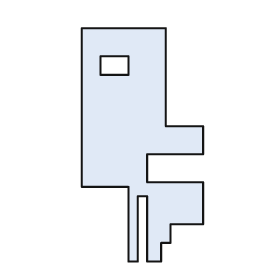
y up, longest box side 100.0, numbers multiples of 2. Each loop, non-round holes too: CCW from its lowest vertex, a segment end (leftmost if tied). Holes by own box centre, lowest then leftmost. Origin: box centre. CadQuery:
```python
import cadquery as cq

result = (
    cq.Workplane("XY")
    .moveTo(-6.0, -50.0)
    .lineTo(-2.0, -50.0)
    .lineTo(-2.0, -22.0)
    .lineTo(2.0, -22.0)
    .lineTo(2.0, -50.0)
    .lineTo(8.0, -50.0)
    .lineTo(8.0, -42.0)
    .lineTo(12.0, -42.0)
    .lineTo(12.0, -34.0)
    .lineTo(26.0, -34.0)
    .lineTo(26.0, -16.0)
    .lineTo(2.0, -16.0)
    .lineTo(2.0, -4.0)
    .lineTo(26.0, -4.0)
    .lineTo(26.0, 8.0)
    .lineTo(10.0, 8.0)
    .lineTo(10.0, 50.0)
    .lineTo(-26.0, 50.0)
    .lineTo(-26.0, -18.0)
    .lineTo(-6.0, -18.0)
    .close()
    .moveTo(-18.0, 30.0)
    .lineTo(-6.0, 30.0)
    .lineTo(-6.0, 38.0)
    .lineTo(-18.0, 38.0)
    .close()
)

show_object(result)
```